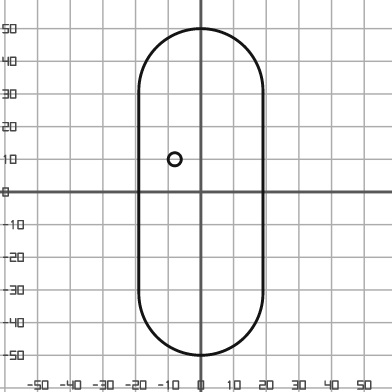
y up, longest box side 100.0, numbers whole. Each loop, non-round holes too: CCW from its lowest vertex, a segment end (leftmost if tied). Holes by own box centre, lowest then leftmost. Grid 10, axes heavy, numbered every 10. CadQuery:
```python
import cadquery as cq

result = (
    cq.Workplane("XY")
    .moveTo(-19.0, -31.0)
    .threePointArc((0.0, -50.0), (19.0, -31.0))
    .lineTo(19.0, 31.0)
    .threePointArc((0.0, 50.0), (-19.0, 31.0))
    .close()
    .moveTo(-8.0, 10.0)
    .circle(2.0)
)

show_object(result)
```